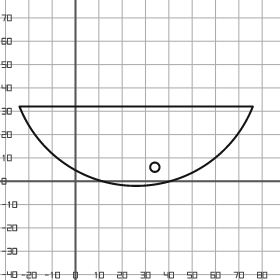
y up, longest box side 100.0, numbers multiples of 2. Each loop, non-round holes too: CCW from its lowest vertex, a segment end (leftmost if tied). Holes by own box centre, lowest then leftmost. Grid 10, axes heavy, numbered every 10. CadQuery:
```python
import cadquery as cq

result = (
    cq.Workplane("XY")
    .moveTo(-24.0, 32.0)
    .threePointArc((26.0, -2.0), (76.0, 32.0))
    .close()
    .moveTo(34.0, 6.0)
    .circle(2.0)
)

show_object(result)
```